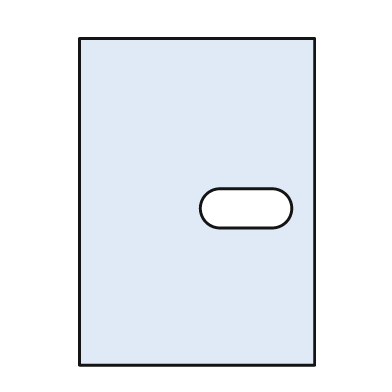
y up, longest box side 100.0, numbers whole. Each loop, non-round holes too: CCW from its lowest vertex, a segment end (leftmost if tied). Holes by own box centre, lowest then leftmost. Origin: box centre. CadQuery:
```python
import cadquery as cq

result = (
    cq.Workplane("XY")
    .moveTo(-36.0, -50.0)
    .lineTo(36.0, -50.0)
    .lineTo(36.0, 50.0)
    .lineTo(-36.0, 50.0)
    .close()
    .moveTo(7.0, -8.0)
    .lineTo(23.0, -8.0)
    .threePointArc((29.0, -2.0), (23.0, 4.0))
    .lineTo(7.0, 4.0)
    .threePointArc((1.0, -2.0), (7.0, -8.0))
    .close()
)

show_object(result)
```